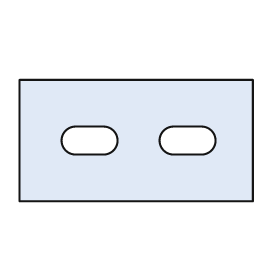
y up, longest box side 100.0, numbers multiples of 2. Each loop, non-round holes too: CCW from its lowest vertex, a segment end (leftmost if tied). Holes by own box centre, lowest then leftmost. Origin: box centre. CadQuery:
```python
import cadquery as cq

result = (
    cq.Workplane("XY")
    .moveTo(-50.0, -26.0)
    .lineTo(50.0, -26.0)
    .lineTo(50.0, 26.0)
    .lineTo(-50.0, 26.0)
    .close()
    .moveTo(-26.0, -6.0)
    .lineTo(-14.0, -6.0)
    .threePointArc((-8.0, 0.0), (-14.0, 6.0))
    .lineTo(-26.0, 6.0)
    .threePointArc((-32.0, 0.0), (-26.0, -6.0))
    .close()
    .moveTo(16.0, -6.0)
    .lineTo(28.0, -6.0)
    .threePointArc((34.0, 0.0), (28.0, 6.0))
    .lineTo(16.0, 6.0)
    .threePointArc((10.0, 0.0), (16.0, -6.0))
    .close()
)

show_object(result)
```